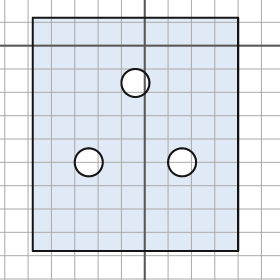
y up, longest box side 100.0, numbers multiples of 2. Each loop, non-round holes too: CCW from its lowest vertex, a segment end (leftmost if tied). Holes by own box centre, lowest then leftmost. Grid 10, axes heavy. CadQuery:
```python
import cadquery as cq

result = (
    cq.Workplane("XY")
    .moveTo(-48.0, -88.0)
    .lineTo(40.0, -88.0)
    .lineTo(40.0, 12.0)
    .lineTo(-48.0, 12.0)
    .close()
    .moveTo(-24.0, -50.0)
    .circle(6.0)
    .moveTo(16.0, -50.0)
    .circle(6.0)
    .moveTo(-4.0, -16.0)
    .circle(6.0)
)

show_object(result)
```